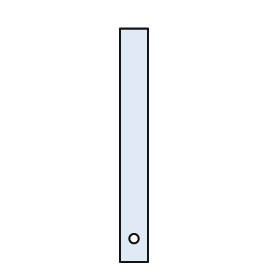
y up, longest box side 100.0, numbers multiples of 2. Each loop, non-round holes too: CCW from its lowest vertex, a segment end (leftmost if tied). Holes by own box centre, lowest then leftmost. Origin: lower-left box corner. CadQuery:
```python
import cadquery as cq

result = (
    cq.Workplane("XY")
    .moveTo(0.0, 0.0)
    .lineTo(12.0, 0.0)
    .lineTo(12.0, 100.0)
    .lineTo(0.0, 100.0)
    .close()
    .moveTo(6.0, 10.0)
    .circle(2.0)
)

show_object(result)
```